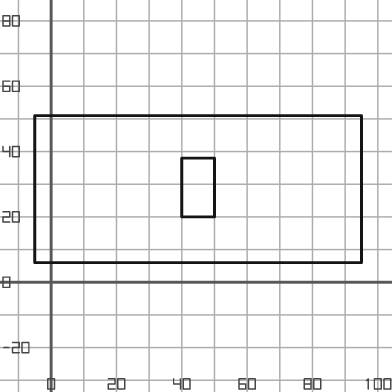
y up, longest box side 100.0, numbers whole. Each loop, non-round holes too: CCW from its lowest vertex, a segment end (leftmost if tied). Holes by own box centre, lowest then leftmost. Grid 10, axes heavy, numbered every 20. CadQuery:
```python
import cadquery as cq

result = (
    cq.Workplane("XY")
    .moveTo(-5.0, 6.0)
    .lineTo(95.0, 6.0)
    .lineTo(95.0, 51.0)
    .lineTo(-5.0, 51.0)
    .close()
    .moveTo(40.0, 20.0)
    .lineTo(50.0, 20.0)
    .lineTo(50.0, 38.0)
    .lineTo(40.0, 38.0)
    .close()
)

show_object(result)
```